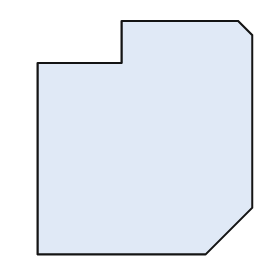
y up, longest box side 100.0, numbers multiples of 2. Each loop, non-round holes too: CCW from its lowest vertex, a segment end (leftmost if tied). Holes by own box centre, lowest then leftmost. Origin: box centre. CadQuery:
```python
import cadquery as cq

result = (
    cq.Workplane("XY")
    .moveTo(-46.0, -50.0)
    .lineTo(26.0, -50.0)
    .lineTo(46.0, -30.0)
    .lineTo(46.0, 44.0)
    .lineTo(40.0, 50.0)
    .lineTo(-10.0, 50.0)
    .lineTo(-10.0, 32.0)
    .lineTo(-46.0, 32.0)
    .close()
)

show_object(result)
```